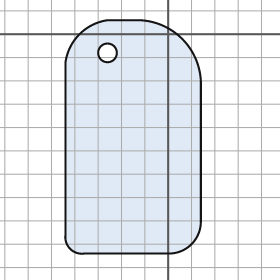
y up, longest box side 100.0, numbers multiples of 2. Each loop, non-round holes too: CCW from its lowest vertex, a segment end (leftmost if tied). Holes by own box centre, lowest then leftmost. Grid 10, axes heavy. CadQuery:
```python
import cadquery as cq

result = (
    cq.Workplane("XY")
    .moveTo(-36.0, -94.0)
    .lineTo(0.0, -94.0)
    .threePointArc((10.0, -90.0), (14.0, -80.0))
    .lineTo(14.0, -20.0)
    .threePointArc((6.0, -2.0), (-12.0, 6.0))
    .lineTo(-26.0, 6.0)
    .threePointArc((-38.0, 0.0), (-44.0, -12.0))
    .lineTo(-44.0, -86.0)
    .threePointArc((-42.0, -92.0), (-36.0, -94.0))
    .close()
    .moveTo(-26.0, -8.0)
    .circle(4.0)
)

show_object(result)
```